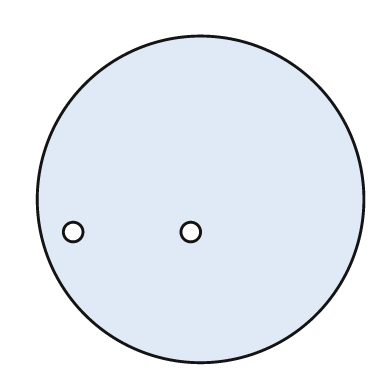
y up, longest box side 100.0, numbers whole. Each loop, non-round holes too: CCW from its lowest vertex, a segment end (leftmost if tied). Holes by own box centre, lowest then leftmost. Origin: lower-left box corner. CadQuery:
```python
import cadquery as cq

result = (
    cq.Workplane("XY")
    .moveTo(50.0, 50.0)
    .circle(50.0)
    .moveTo(11.0, 40.0)
    .circle(3.0)
    .moveTo(47.0, 40.0)
    .circle(3.0)
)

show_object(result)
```